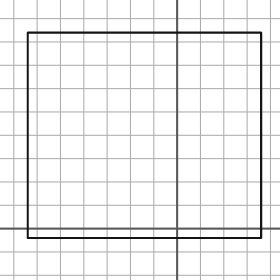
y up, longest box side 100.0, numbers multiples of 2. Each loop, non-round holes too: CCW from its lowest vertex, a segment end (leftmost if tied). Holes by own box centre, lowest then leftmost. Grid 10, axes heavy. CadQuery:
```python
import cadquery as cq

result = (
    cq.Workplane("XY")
    .moveTo(-64.0, -4.0)
    .lineTo(36.0, -4.0)
    .lineTo(36.0, 84.0)
    .lineTo(-64.0, 84.0)
    .close()
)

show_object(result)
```